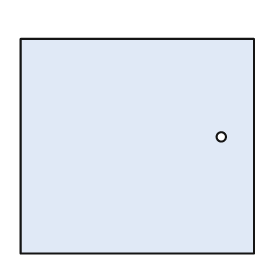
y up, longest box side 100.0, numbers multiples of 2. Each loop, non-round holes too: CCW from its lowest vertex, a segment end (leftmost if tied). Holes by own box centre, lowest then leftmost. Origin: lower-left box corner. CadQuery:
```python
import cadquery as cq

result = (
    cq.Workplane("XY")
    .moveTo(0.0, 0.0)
    .lineTo(100.0, 0.0)
    .lineTo(100.0, 92.0)
    .lineTo(0.0, 92.0)
    .close()
    .moveTo(86.0, 50.0)
    .circle(2.0)
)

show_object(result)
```